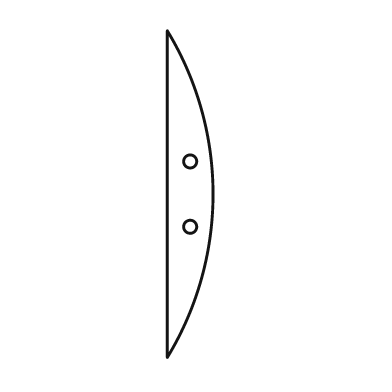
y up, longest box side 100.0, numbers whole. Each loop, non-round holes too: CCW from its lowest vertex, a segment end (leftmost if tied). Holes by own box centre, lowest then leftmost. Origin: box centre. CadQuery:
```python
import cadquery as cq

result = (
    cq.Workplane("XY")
    .moveTo(-7.0, -50.0)
    .threePointArc((7.0, 0.0), (-7.0, 50.0))
    .close()
    .moveTo(0.0, -10.0)
    .circle(2.0)
    .moveTo(0.0, 10.0)
    .circle(2.0)
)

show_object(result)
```